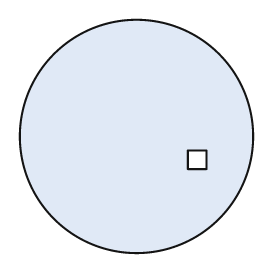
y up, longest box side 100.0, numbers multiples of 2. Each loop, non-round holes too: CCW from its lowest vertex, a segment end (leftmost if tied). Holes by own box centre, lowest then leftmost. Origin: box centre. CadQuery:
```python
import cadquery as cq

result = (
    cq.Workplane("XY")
    .moveTo(0.0, 0.0)
    .circle(50.0)
    .moveTo(22.0, -14.0)
    .lineTo(30.0, -14.0)
    .lineTo(30.0, -6.0)
    .lineTo(22.0, -6.0)
    .close()
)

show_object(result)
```